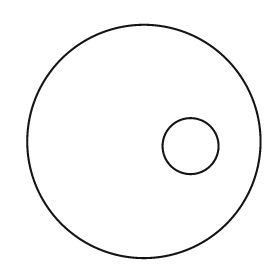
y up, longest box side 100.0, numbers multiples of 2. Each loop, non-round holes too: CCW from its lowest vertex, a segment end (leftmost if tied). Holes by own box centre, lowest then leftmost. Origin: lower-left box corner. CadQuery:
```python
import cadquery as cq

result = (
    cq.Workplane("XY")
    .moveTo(50.0, 50.0)
    .circle(50.0)
    .moveTo(70.0, 48.0)
    .circle(12.0)
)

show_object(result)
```